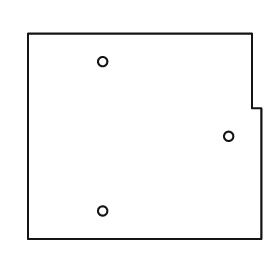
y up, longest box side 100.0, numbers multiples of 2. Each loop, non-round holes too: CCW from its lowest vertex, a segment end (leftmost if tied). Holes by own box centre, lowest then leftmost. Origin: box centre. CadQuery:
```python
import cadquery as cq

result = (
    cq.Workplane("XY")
    .moveTo(-50.0, -44.0)
    .lineTo(50.0, -44.0)
    .lineTo(50.0, 12.0)
    .lineTo(46.0, 12.0)
    .lineTo(46.0, 44.0)
    .lineTo(-50.0, 44.0)
    .close()
    .moveTo(-18.0, -32.0)
    .circle(2.0)
    .moveTo(36.0, 0.0)
    .circle(2.0)
    .moveTo(-18.0, 32.0)
    .circle(2.0)
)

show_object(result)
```